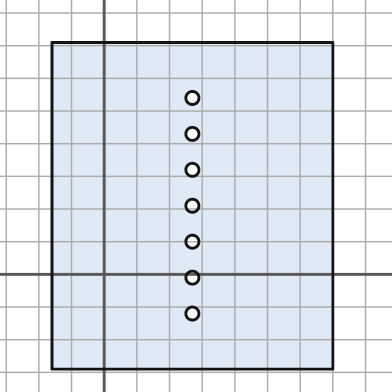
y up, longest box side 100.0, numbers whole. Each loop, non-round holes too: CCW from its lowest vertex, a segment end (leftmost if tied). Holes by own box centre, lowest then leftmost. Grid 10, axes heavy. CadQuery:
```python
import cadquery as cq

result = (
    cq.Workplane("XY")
    .moveTo(-16.0, -29.0)
    .lineTo(70.0, -29.0)
    .lineTo(70.0, 71.0)
    .lineTo(-16.0, 71.0)
    .close()
    .moveTo(27.0, -12.0)
    .circle(2.0)
    .moveTo(27.0, -1.0)
    .circle(2.0)
    .moveTo(27.0, 10.0)
    .circle(2.0)
    .moveTo(27.0, 21.0)
    .circle(2.0)
    .moveTo(27.0, 32.0)
    .circle(2.0)
    .moveTo(27.0, 43.0)
    .circle(2.0)
    .moveTo(27.0, 54.0)
    .circle(2.0)
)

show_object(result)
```